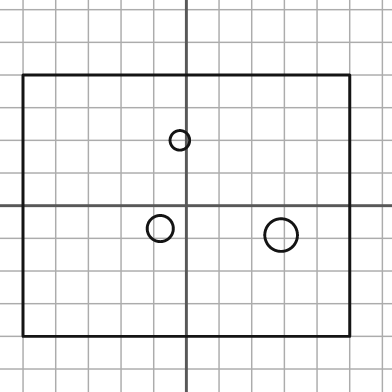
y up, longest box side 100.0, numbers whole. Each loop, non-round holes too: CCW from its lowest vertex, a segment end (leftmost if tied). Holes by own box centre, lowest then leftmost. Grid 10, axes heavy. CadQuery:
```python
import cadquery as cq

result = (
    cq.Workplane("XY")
    .moveTo(-50.0, -40.0)
    .lineTo(50.0, -40.0)
    .lineTo(50.0, 40.0)
    .lineTo(-50.0, 40.0)
    .close()
    .moveTo(29.0, -9.0)
    .circle(5.0)
    .moveTo(-8.0, -7.0)
    .circle(4.0)
    .moveTo(-2.0, 20.0)
    .circle(3.0)
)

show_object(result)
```